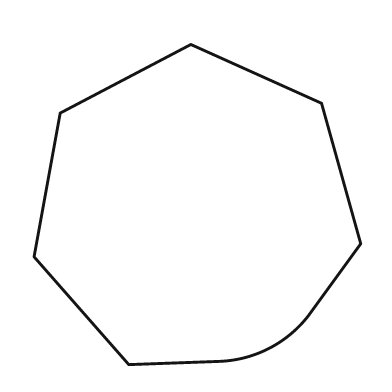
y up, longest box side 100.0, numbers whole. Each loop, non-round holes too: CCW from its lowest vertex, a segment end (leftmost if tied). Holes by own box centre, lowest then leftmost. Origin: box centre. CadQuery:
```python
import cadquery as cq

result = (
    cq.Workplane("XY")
    .moveTo(-21.0, -49.0)
    .lineTo(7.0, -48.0)
    .threePointArc((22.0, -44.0), (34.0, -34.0))
    .lineTo(50.0, -12.0)
    .lineTo(38.0, 31.0)
    .lineTo(-2.0, 49.0)
    .lineTo(-42.0, 28.0)
    .lineTo(-50.0, -16.0)
    .close()
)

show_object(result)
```